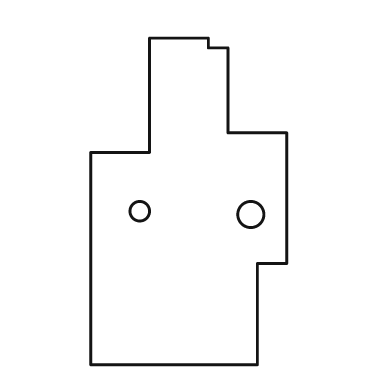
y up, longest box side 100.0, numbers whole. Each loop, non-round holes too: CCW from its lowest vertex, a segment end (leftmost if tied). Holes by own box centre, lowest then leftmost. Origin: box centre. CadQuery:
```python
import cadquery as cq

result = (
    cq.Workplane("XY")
    .moveTo(-30.0, -50.0)
    .lineTo(21.0, -50.0)
    .lineTo(21.0, -19.0)
    .lineTo(30.0, -19.0)
    .lineTo(30.0, 21.0)
    .lineTo(12.0, 21.0)
    .lineTo(12.0, 47.0)
    .lineTo(6.0, 47.0)
    .lineTo(6.0, 50.0)
    .lineTo(-12.0, 50.0)
    .lineTo(-12.0, 15.0)
    .lineTo(-30.0, 15.0)
    .close()
    .moveTo(19.0, -4.0)
    .circle(4.0)
    .moveTo(-15.0, -3.0)
    .circle(3.0)
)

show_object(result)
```